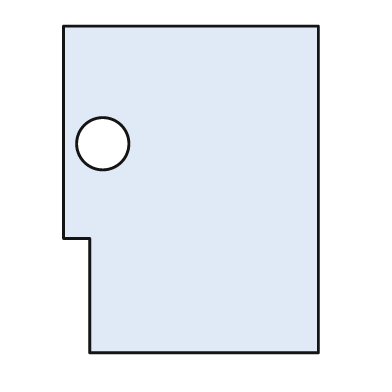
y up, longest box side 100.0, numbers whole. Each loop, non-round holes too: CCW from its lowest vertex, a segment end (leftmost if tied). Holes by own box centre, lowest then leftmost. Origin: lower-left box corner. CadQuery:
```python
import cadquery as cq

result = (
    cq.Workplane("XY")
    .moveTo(8.0, 0.0)
    .lineTo(78.0, 0.0)
    .lineTo(78.0, 100.0)
    .lineTo(0.0, 100.0)
    .lineTo(0.0, 35.0)
    .lineTo(8.0, 35.0)
    .close()
    .moveTo(12.0, 64.0)
    .circle(8.0)
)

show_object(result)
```